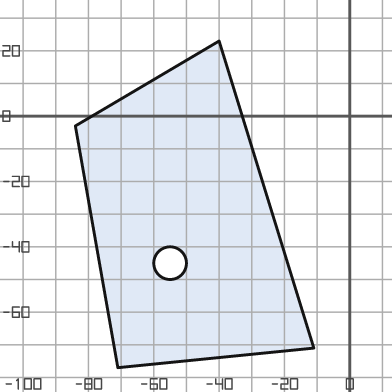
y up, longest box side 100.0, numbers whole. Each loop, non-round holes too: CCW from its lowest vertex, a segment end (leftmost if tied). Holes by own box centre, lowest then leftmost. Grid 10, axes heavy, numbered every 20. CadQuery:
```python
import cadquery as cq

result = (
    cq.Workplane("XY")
    .moveTo(-71.0, -77.0)
    .lineTo(-11.0, -71.0)
    .lineTo(-40.0, 23.0)
    .lineTo(-84.0, -3.0)
    .close()
    .moveTo(-55.0, -45.0)
    .circle(5.0)
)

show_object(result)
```